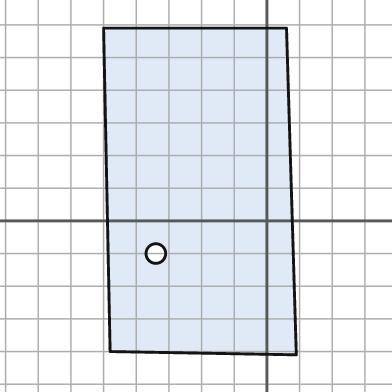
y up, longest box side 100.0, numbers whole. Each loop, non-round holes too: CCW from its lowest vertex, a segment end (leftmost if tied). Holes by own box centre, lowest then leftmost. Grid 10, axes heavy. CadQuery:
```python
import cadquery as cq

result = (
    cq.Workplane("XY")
    .moveTo(9.0, -41.0)
    .lineTo(6.0, 59.0)
    .lineTo(-50.0, 59.0)
    .lineTo(-48.0, -40.0)
    .close()
    .moveTo(-34.0, -10.0)
    .circle(3.0)
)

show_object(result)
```